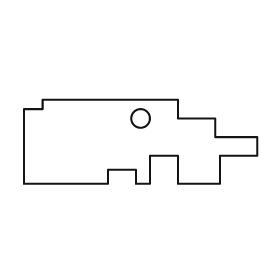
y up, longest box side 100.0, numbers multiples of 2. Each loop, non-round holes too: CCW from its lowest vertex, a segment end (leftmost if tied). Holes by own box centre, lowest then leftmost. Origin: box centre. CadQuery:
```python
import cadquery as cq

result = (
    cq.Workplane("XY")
    .moveTo(-50.0, -18.0)
    .lineTo(-14.0, -18.0)
    .lineTo(-14.0, -12.0)
    .lineTo(-2.0, -12.0)
    .lineTo(-2.0, -18.0)
    .lineTo(4.0, -18.0)
    .lineTo(4.0, -6.0)
    .lineTo(16.0, -6.0)
    .lineTo(16.0, -18.0)
    .lineTo(34.0, -18.0)
    .lineTo(34.0, -6.0)
    .lineTo(50.0, -6.0)
    .lineTo(50.0, 2.0)
    .lineTo(32.0, 2.0)
    .lineTo(32.0, 10.0)
    .lineTo(16.0, 10.0)
    .lineTo(16.0, 18.0)
    .lineTo(-42.0, 18.0)
    .lineTo(-42.0, 14.0)
    .lineTo(-50.0, 14.0)
    .close()
    .moveTo(0.0, 10.0)
    .circle(4.0)
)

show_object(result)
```